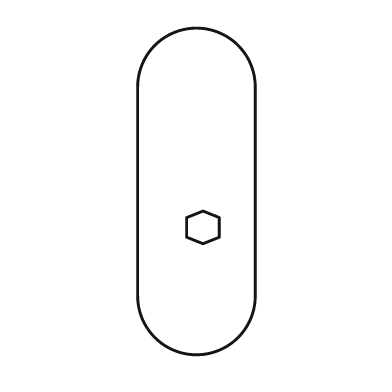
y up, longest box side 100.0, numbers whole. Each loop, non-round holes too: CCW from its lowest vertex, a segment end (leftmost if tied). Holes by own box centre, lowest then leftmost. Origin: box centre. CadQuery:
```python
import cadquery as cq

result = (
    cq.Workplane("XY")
    .moveTo(-18.0, -32.0)
    .threePointArc((0.0, -50.0), (18.0, -32.0))
    .lineTo(18.0, 32.0)
    .threePointArc((0.0, 50.0), (-18.0, 32.0))
    .close()
    .moveTo(2.0, -16.0)
    .lineTo(7.0, -14.0)
    .lineTo(7.0, -8.0)
    .lineTo(2.0, -6.0)
    .lineTo(-3.0, -8.0)
    .lineTo(-3.0, -14.0)
    .close()
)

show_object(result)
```